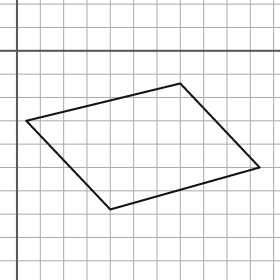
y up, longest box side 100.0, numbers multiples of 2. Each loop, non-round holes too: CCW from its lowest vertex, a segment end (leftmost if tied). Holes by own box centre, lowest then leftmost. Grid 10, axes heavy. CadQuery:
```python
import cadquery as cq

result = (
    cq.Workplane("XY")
    .moveTo(40.0, -68.0)
    .lineTo(104.0, -50.0)
    .lineTo(70.0, -14.0)
    .lineTo(4.0, -30.0)
    .close()
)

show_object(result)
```